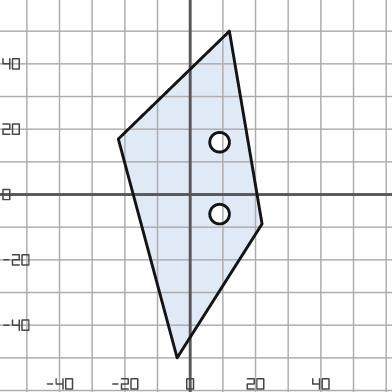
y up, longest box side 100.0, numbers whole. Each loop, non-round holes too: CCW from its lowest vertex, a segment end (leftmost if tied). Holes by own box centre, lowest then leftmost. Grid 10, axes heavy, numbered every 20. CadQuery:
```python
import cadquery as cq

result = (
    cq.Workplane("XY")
    .moveTo(-4.0, -50.0)
    .lineTo(22.0, -9.0)
    .lineTo(12.0, 50.0)
    .lineTo(-22.0, 17.0)
    .close()
    .moveTo(9.0, -6.0)
    .circle(3.0)
    .moveTo(9.0, 16.0)
    .circle(3.0)
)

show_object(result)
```